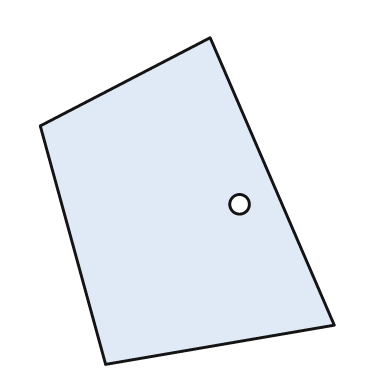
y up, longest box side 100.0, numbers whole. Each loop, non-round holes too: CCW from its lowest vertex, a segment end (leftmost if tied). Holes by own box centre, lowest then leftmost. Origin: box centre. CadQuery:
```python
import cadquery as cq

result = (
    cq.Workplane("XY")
    .moveTo(-25.0, -50.0)
    .lineTo(45.0, -38.0)
    .lineTo(7.0, 50.0)
    .lineTo(-45.0, 23.0)
    .close()
    .moveTo(16.0, -1.0)
    .circle(3.0)
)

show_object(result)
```